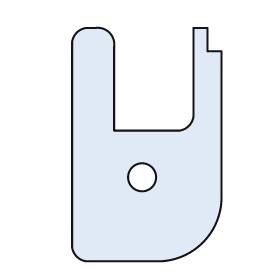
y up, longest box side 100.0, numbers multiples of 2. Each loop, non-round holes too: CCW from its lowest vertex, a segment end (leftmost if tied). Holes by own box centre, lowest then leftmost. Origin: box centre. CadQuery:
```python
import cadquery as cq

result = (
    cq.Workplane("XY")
    .moveTo(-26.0, -50.0)
    .lineTo(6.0, -50.0)
    .threePointArc((24.0, -42.0), (32.0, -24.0))
    .lineTo(32.0, 40.0)
    .lineTo(26.0, 40.0)
    .lineTo(26.0, 50.0)
    .lineTo(20.0, 50.0)
    .lineTo(20.0, 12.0)
    .threePointArc((18.0, 8.0), (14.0, 6.0))
    .lineTo(-14.0, 6.0)
    .lineTo(-14.0, 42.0)
    .threePointArc((-16.0, 48.0), (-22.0, 50.0))
    .lineTo(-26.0, 50.0)
    .threePointArc((-30.0, 48.0), (-32.0, 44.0))
    .lineTo(-32.0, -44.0)
    .threePointArc((-30.0, -48.0), (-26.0, -50.0))
    .close()
    .moveTo(-2.0, -14.0)
    .circle(6.0)
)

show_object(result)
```